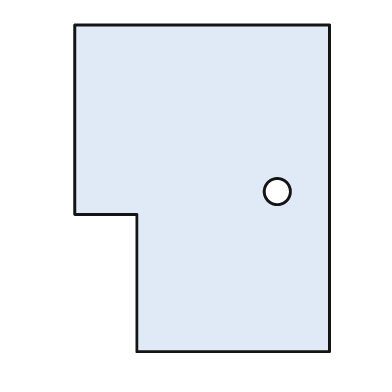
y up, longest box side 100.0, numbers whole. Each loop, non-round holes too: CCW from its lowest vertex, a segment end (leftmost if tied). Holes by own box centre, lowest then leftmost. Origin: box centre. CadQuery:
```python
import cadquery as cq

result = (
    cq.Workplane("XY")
    .moveTo(-20.0, -50.0)
    .lineTo(39.0, -50.0)
    .lineTo(39.0, 50.0)
    .lineTo(-39.0, 50.0)
    .lineTo(-39.0, -8.0)
    .lineTo(-20.0, -8.0)
    .close()
    .moveTo(23.0, -1.0)
    .circle(4.0)
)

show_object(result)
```